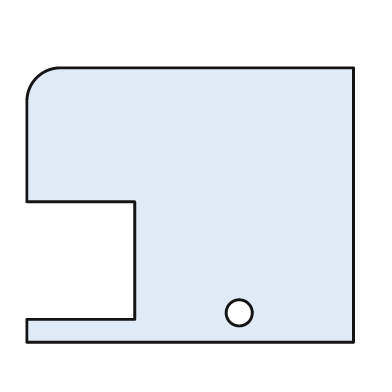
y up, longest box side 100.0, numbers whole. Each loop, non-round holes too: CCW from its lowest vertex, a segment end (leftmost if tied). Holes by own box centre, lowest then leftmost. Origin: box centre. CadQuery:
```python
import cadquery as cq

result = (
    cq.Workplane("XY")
    .moveTo(-50.0, -42.0)
    .lineTo(50.0, -42.0)
    .lineTo(50.0, 42.0)
    .lineTo(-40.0, 42.0)
    .threePointArc((-47.0, 39.0), (-50.0, 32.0))
    .lineTo(-50.0, 1.0)
    .lineTo(-17.0, 1.0)
    .lineTo(-17.0, -35.0)
    .lineTo(-50.0, -35.0)
    .close()
    .moveTo(15.0, -33.0)
    .circle(4.0)
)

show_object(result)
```